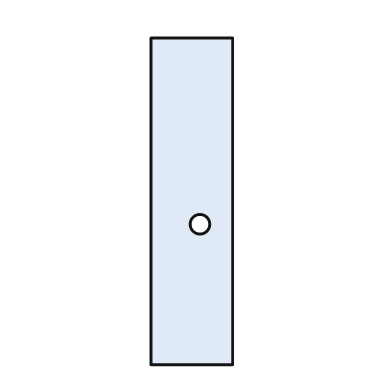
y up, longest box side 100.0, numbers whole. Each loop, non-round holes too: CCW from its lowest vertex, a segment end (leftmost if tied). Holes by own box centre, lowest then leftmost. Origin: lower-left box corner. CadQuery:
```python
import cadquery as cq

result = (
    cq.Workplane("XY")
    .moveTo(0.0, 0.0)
    .lineTo(25.0, 0.0)
    .lineTo(25.0, 100.0)
    .lineTo(0.0, 100.0)
    .close()
    .moveTo(15.0, 43.0)
    .circle(3.0)
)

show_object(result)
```